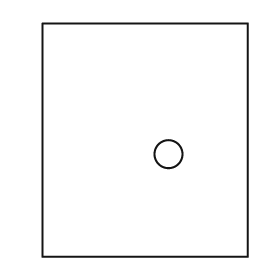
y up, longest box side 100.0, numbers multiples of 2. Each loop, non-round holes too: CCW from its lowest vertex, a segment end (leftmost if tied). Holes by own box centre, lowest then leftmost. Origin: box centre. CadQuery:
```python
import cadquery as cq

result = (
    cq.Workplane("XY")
    .moveTo(-44.0, -50.0)
    .lineTo(44.0, -50.0)
    .lineTo(44.0, 50.0)
    .lineTo(-44.0, 50.0)
    .close()
    .moveTo(10.0, -6.0)
    .circle(6.0)
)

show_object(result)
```